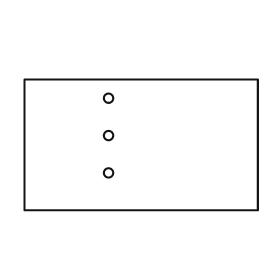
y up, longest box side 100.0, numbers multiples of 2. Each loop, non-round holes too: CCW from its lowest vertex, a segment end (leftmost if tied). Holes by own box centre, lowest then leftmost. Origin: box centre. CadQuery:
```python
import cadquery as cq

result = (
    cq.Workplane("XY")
    .moveTo(-50.0, -28.0)
    .lineTo(50.0, -28.0)
    .lineTo(50.0, 28.0)
    .lineTo(-50.0, 28.0)
    .close()
    .moveTo(-14.0, -12.0)
    .circle(2.0)
    .moveTo(-14.0, 4.0)
    .circle(2.0)
    .moveTo(-14.0, 20.0)
    .circle(2.0)
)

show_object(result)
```